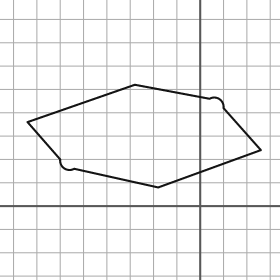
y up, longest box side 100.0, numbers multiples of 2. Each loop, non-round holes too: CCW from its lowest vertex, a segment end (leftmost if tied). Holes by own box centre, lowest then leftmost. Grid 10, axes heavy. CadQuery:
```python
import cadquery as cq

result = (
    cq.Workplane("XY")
    .moveTo(-18.0, 8.0)
    .lineTo(26.0, 24.0)
    .lineTo(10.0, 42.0)
    .threePointArc((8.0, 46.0), (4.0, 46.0))
    .lineTo(-28.0, 52.0)
    .lineTo(-74.0, 36.0)
    .lineTo(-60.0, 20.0)
    .threePointArc((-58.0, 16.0), (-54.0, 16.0))
    .close()
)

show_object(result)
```